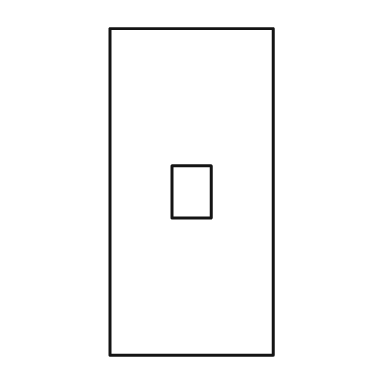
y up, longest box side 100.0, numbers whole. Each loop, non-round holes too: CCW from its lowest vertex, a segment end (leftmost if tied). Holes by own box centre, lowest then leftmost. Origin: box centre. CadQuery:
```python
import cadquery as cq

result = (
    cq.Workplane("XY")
    .moveTo(-25.0, -50.0)
    .lineTo(25.0, -50.0)
    .lineTo(25.0, 50.0)
    .lineTo(-25.0, 50.0)
    .close()
    .moveTo(-6.0, -8.0)
    .lineTo(6.0, -8.0)
    .lineTo(6.0, 8.0)
    .lineTo(-6.0, 8.0)
    .close()
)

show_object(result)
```